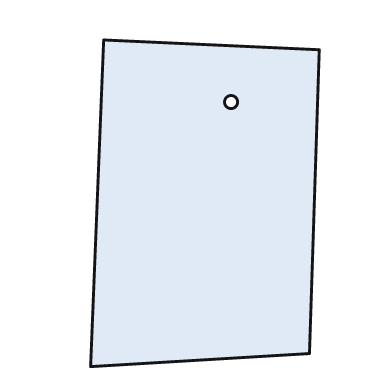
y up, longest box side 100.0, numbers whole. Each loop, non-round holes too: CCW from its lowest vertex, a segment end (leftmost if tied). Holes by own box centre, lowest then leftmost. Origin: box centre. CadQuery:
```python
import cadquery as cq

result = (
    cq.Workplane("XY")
    .moveTo(-35.0, -50.0)
    .lineTo(32.0, -46.0)
    .lineTo(35.0, 47.0)
    .lineTo(-31.0, 50.0)
    .close()
    .moveTo(8.0, 31.0)
    .circle(2.0)
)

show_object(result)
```